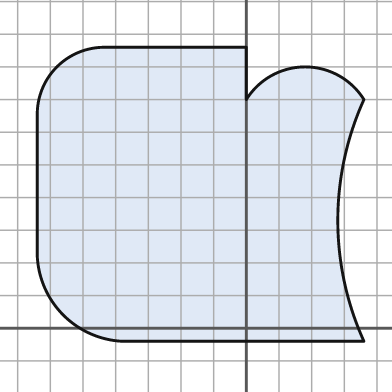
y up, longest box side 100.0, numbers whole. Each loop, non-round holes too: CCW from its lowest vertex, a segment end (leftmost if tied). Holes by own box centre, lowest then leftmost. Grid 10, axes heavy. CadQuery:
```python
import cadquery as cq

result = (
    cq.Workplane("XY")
    .moveTo(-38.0, -4.0)
    .lineTo(36.0, -4.0)
    .threePointArc((28.0, 33.0), (36.0, 70.0))
    .threePointArc((18.0, 80.0), (0.0, 70.0))
    .lineTo(0.0, 86.0)
    .lineTo(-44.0, 86.0)
    .threePointArc((-58.0, 80.0), (-64.0, 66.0))
    .lineTo(-64.0, 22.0)
    .threePointArc((-56.0, 4.0), (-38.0, -4.0))
    .close()
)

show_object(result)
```